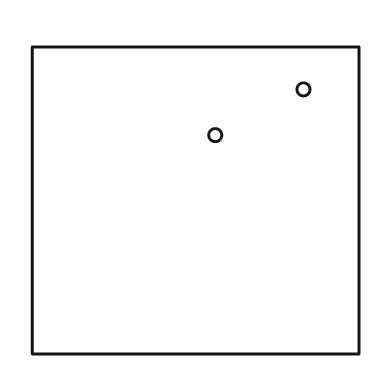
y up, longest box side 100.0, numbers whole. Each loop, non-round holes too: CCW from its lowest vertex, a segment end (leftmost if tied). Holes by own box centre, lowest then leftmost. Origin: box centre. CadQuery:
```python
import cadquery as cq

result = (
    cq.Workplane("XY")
    .moveTo(-50.0, -47.0)
    .lineTo(50.0, -47.0)
    .lineTo(50.0, 47.0)
    .lineTo(-50.0, 47.0)
    .close()
    .moveTo(6.0, 20.0)
    .circle(2.0)
    .moveTo(33.0, 34.0)
    .circle(2.0)
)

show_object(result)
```